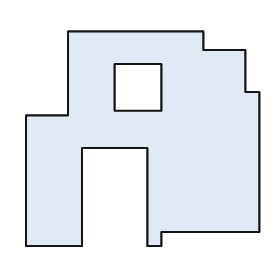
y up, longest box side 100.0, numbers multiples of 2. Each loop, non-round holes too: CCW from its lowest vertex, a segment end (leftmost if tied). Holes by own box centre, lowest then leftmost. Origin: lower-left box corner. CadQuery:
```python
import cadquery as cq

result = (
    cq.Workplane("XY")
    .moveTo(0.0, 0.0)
    .lineTo(24.0, 0.0)
    .lineTo(24.0, 42.0)
    .lineTo(52.0, 42.0)
    .lineTo(52.0, 0.0)
    .lineTo(58.0, 0.0)
    .lineTo(58.0, 6.0)
    .lineTo(100.0, 6.0)
    .lineTo(100.0, 66.0)
    .lineTo(94.0, 66.0)
    .lineTo(94.0, 84.0)
    .lineTo(76.0, 84.0)
    .lineTo(76.0, 92.0)
    .lineTo(18.0, 92.0)
    .lineTo(18.0, 56.0)
    .lineTo(0.0, 56.0)
    .close()
    .moveTo(38.0, 58.0)
    .lineTo(58.0, 58.0)
    .lineTo(58.0, 78.0)
    .lineTo(38.0, 78.0)
    .close()
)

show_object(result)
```